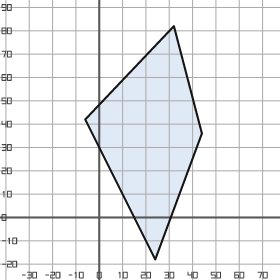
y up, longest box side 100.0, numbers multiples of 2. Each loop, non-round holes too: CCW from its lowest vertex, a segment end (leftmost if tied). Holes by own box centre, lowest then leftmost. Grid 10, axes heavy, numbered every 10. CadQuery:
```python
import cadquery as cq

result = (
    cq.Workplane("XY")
    .moveTo(24.0, -18.0)
    .lineTo(44.0, 36.0)
    .lineTo(32.0, 82.0)
    .lineTo(-6.0, 42.0)
    .close()
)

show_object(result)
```